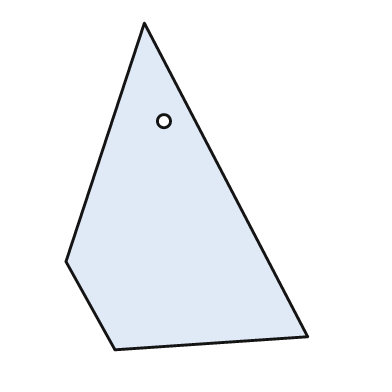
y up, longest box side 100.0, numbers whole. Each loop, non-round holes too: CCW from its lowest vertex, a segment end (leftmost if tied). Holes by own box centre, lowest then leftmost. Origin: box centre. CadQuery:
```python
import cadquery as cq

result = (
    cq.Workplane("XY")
    .moveTo(-22.0, -50.0)
    .lineTo(37.0, -46.0)
    .lineTo(-13.0, 50.0)
    .lineTo(-37.0, -23.0)
    .close()
    .moveTo(-7.0, 20.0)
    .circle(2.0)
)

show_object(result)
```